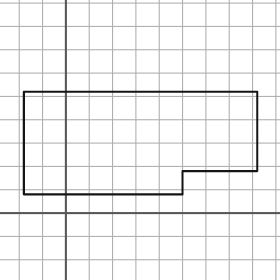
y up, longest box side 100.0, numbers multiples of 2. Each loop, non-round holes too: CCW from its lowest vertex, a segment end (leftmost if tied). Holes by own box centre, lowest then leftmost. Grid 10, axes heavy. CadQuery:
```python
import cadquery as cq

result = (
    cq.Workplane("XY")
    .moveTo(-18.0, 8.0)
    .lineTo(50.0, 8.0)
    .lineTo(50.0, 18.0)
    .lineTo(82.0, 18.0)
    .lineTo(82.0, 52.0)
    .lineTo(-18.0, 52.0)
    .close()
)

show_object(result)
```